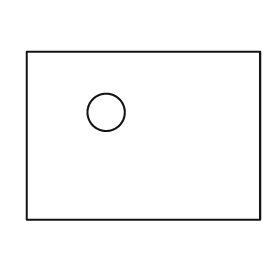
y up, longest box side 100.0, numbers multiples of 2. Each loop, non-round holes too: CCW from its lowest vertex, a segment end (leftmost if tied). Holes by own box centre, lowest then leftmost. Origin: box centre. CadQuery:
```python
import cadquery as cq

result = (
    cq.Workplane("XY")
    .moveTo(-50.0, -36.0)
    .lineTo(50.0, -36.0)
    .lineTo(50.0, 36.0)
    .lineTo(-50.0, 36.0)
    .close()
    .moveTo(-16.0, 10.0)
    .circle(8.0)
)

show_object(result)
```